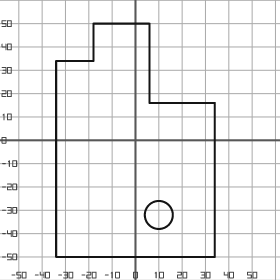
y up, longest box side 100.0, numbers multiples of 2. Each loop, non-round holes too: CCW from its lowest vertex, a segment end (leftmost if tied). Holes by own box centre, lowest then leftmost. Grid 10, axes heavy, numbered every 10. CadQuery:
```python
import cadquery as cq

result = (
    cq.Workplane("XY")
    .moveTo(-34.0, -50.0)
    .lineTo(34.0, -50.0)
    .lineTo(34.0, 16.0)
    .lineTo(6.0, 16.0)
    .lineTo(6.0, 50.0)
    .lineTo(-18.0, 50.0)
    .lineTo(-18.0, 34.0)
    .lineTo(-34.0, 34.0)
    .close()
    .moveTo(10.0, -32.0)
    .circle(6.0)
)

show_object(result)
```